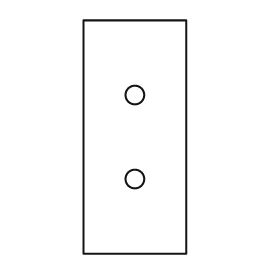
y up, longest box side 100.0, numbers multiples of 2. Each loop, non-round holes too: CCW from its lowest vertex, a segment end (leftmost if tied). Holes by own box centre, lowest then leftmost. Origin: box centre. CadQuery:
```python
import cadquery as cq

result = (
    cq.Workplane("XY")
    .moveTo(-22.0, -50.0)
    .lineTo(22.0, -50.0)
    .lineTo(22.0, 50.0)
    .lineTo(-22.0, 50.0)
    .close()
    .moveTo(0.0, -18.0)
    .circle(4.0)
    .moveTo(0.0, 18.0)
    .circle(4.0)
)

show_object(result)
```